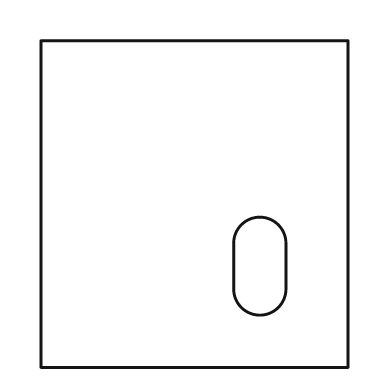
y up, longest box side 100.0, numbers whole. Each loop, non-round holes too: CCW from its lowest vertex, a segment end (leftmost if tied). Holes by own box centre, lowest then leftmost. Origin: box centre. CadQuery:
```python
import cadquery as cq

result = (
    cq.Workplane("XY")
    .moveTo(-47.0, -50.0)
    .lineTo(47.0, -50.0)
    .lineTo(47.0, 50.0)
    .lineTo(-47.0, 50.0)
    .close()
    .moveTo(12.0, -26.0)
    .threePointArc((20.0, -34.0), (28.0, -26.0))
    .lineTo(28.0, -12.0)
    .threePointArc((20.0, -4.0), (12.0, -12.0))
    .close()
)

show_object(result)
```